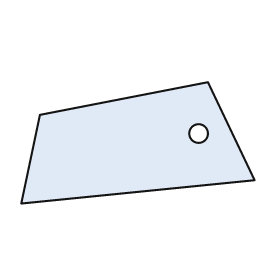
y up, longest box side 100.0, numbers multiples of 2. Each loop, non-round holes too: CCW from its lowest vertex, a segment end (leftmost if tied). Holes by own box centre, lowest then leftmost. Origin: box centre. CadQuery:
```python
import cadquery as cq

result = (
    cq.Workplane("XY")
    .moveTo(-50.0, -26.0)
    .lineTo(50.0, -16.0)
    .lineTo(30.0, 26.0)
    .lineTo(-42.0, 12.0)
    .close()
    .moveTo(26.0, 4.0)
    .circle(4.0)
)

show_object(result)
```